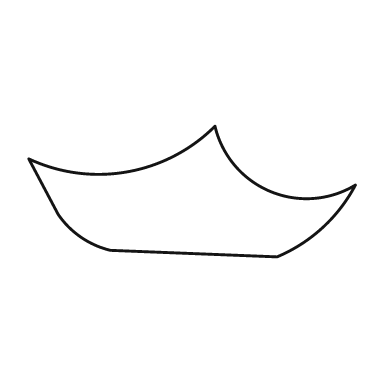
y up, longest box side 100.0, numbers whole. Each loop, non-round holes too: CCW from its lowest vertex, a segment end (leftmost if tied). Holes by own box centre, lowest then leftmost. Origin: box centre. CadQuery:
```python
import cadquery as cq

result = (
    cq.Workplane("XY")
    .moveTo(26.0, -20.0)
    .threePointArc((40.0, -11.0), (50.0, 2.0))
    .threePointArc((24.0, 0.0), (7.0, 20.0))
    .threePointArc((-20.0, 6.0), (-50.0, 10.0))
    .lineTo(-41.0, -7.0)
    .threePointArc((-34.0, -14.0), (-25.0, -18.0))
    .close()
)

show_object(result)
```